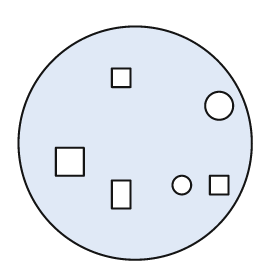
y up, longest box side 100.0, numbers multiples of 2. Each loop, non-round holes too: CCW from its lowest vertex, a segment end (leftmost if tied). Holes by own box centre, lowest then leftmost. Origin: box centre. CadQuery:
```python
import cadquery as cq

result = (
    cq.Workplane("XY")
    .moveTo(0.0, 0.0)
    .circle(50.0)
    .moveTo(-10.0, -28.0)
    .lineTo(-2.0, -28.0)
    .lineTo(-2.0, -16.0)
    .lineTo(-10.0, -16.0)
    .close()
    .moveTo(20.0, -18.0)
    .circle(4.0)
    .moveTo(32.0, -22.0)
    .lineTo(40.0, -22.0)
    .lineTo(40.0, -14.0)
    .lineTo(32.0, -14.0)
    .close()
    .moveTo(-34.0, -14.0)
    .lineTo(-22.0, -14.0)
    .lineTo(-22.0, -2.0)
    .lineTo(-34.0, -2.0)
    .close()
    .moveTo(36.0, 16.0)
    .circle(6.0)
    .moveTo(-10.0, 24.0)
    .lineTo(-2.0, 24.0)
    .lineTo(-2.0, 32.0)
    .lineTo(-10.0, 32.0)
    .close()
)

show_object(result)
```